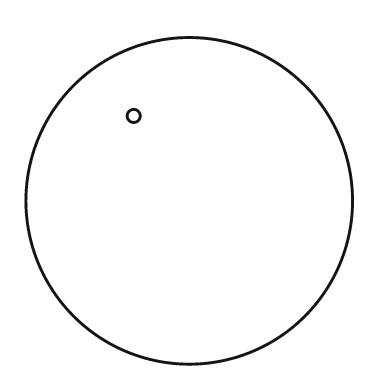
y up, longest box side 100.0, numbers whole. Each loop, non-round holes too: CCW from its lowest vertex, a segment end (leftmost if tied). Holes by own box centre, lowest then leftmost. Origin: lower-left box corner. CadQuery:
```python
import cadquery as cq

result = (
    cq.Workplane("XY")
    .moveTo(50.0, 50.0)
    .circle(50.0)
    .moveTo(33.0, 76.0)
    .circle(2.0)
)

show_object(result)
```